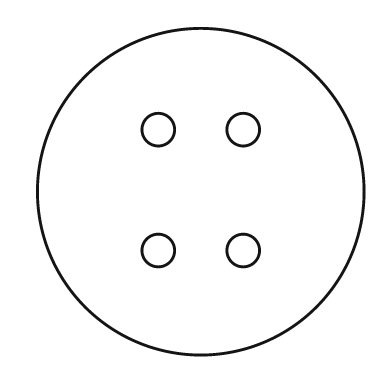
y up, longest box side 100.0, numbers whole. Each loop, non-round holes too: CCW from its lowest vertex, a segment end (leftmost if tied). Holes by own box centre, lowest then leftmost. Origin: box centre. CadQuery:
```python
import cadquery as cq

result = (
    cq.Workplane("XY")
    .moveTo(0.0, 0.0)
    .circle(50.0)
    .moveTo(-13.0, -18.0)
    .circle(5.0)
    .moveTo(13.0, -18.0)
    .circle(5.0)
    .moveTo(-13.0, 19.0)
    .circle(5.0)
    .moveTo(13.0, 19.0)
    .circle(5.0)
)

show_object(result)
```